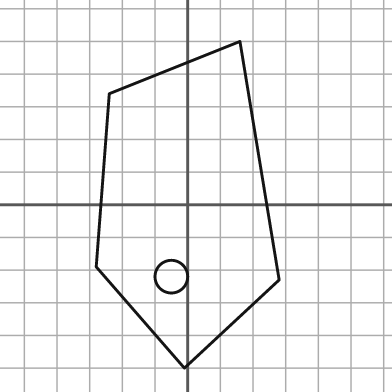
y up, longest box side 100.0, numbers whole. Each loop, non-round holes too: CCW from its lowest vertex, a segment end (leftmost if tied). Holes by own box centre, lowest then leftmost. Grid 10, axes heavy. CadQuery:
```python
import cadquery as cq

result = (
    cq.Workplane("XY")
    .moveTo(-1.0, -50.0)
    .lineTo(28.0, -23.0)
    .lineTo(16.0, 50.0)
    .lineTo(-24.0, 34.0)
    .lineTo(-28.0, -19.0)
    .close()
    .moveTo(-5.0, -22.0)
    .circle(5.0)
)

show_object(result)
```